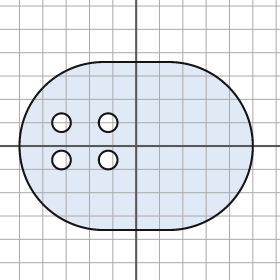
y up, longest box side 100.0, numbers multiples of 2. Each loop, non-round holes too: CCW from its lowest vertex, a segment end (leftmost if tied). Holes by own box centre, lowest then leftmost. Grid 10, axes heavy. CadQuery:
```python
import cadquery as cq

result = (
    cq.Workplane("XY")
    .moveTo(-14.0, -36.0)
    .lineTo(14.0, -36.0)
    .threePointArc((50.0, 0.0), (14.0, 36.0))
    .lineTo(-14.0, 36.0)
    .threePointArc((-50.0, 0.0), (-14.0, -36.0))
    .close()
    .moveTo(-32.0, -6.0)
    .circle(4.0)
    .moveTo(-12.0, -6.0)
    .circle(4.0)
    .moveTo(-32.0, 10.0)
    .circle(4.0)
    .moveTo(-12.0, 10.0)
    .circle(4.0)
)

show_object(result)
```